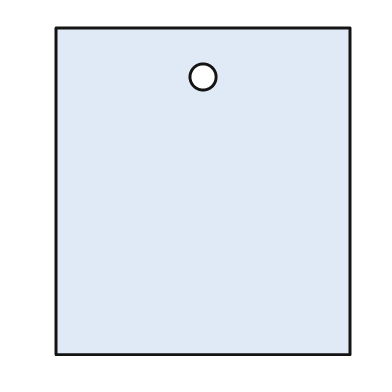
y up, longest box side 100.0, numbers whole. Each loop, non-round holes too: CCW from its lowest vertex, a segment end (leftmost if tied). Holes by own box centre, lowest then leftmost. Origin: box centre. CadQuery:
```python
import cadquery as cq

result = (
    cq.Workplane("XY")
    .moveTo(-45.0, -50.0)
    .lineTo(45.0, -50.0)
    .lineTo(45.0, 50.0)
    .lineTo(-45.0, 50.0)
    .close()
    .moveTo(0.0, 35.0)
    .circle(4.0)
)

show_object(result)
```